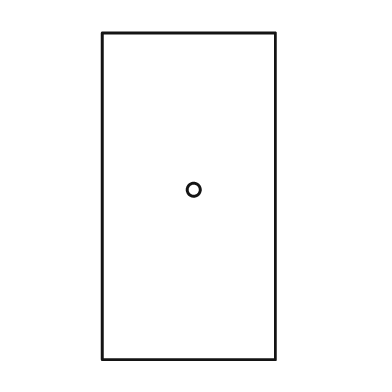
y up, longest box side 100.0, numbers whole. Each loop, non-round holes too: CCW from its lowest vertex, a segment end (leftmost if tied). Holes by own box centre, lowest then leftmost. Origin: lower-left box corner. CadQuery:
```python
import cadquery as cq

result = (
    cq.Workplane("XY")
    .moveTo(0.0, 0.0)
    .lineTo(53.0, 0.0)
    .lineTo(53.0, 100.0)
    .lineTo(0.0, 100.0)
    .close()
    .moveTo(28.0, 52.0)
    .circle(2.0)
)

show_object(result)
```